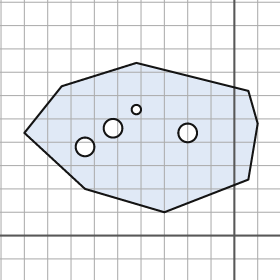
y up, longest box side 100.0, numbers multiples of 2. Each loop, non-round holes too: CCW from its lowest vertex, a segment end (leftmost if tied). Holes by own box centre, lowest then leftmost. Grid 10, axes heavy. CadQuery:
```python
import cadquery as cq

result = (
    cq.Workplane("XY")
    .moveTo(-30.0, 10.0)
    .lineTo(6.0, 24.0)
    .lineTo(10.0, 48.0)
    .lineTo(6.0, 62.0)
    .lineTo(-42.0, 74.0)
    .lineTo(-74.0, 64.0)
    .lineTo(-90.0, 44.0)
    .lineTo(-64.0, 20.0)
    .close()
    .moveTo(-64.0, 38.0)
    .circle(4.0)
    .moveTo(-20.0, 44.0)
    .circle(4.0)
    .moveTo(-52.0, 46.0)
    .circle(4.0)
    .moveTo(-42.0, 54.0)
    .circle(2.0)
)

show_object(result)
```